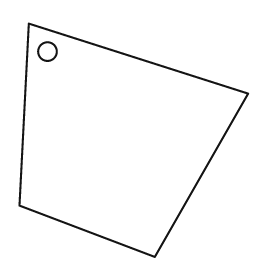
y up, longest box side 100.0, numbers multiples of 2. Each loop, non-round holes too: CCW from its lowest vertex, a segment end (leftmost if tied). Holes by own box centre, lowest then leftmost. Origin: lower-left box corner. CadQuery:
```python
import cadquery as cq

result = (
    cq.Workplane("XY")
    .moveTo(58.0, 0.0)
    .lineTo(98.0, 70.0)
    .lineTo(4.0, 100.0)
    .lineTo(0.0, 22.0)
    .close()
    .moveTo(12.0, 88.0)
    .circle(4.0)
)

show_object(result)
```